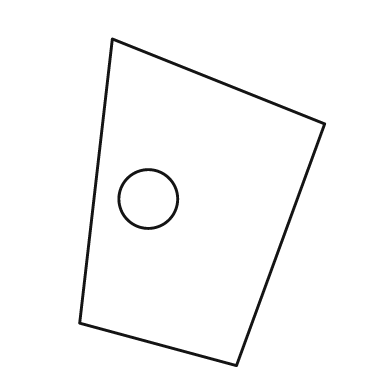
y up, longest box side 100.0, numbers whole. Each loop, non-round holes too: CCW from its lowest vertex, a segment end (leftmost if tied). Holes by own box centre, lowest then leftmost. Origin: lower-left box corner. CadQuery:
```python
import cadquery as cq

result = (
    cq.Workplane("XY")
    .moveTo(48.0, 0.0)
    .lineTo(75.0, 74.0)
    .lineTo(10.0, 100.0)
    .lineTo(0.0, 13.0)
    .close()
    .moveTo(21.0, 51.0)
    .circle(9.0)
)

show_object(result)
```